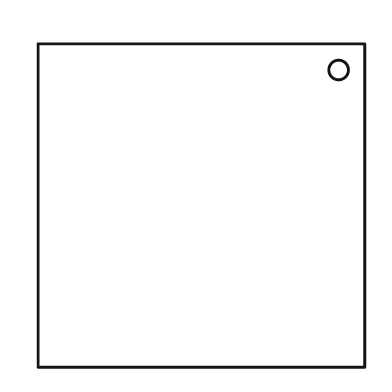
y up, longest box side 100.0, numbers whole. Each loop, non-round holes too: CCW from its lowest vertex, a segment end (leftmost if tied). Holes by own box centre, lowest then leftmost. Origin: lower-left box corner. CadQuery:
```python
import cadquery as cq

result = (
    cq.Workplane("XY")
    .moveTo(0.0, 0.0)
    .lineTo(100.0, 0.0)
    .lineTo(100.0, 99.0)
    .lineTo(0.0, 99.0)
    .close()
    .moveTo(92.0, 91.0)
    .circle(3.0)
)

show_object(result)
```